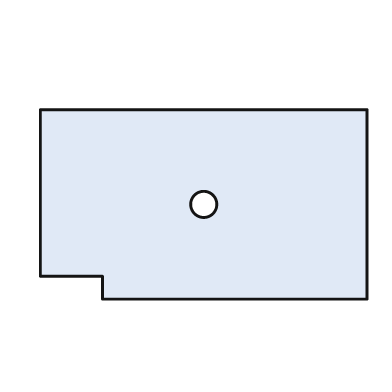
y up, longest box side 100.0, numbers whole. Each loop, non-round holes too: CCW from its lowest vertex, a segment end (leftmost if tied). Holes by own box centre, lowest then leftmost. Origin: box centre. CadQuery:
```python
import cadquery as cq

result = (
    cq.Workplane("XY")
    .moveTo(-31.0, -29.0)
    .lineTo(50.0, -29.0)
    .lineTo(50.0, 29.0)
    .lineTo(-50.0, 29.0)
    .lineTo(-50.0, -22.0)
    .lineTo(-31.0, -22.0)
    .close()
    .moveTo(0.0, 0.0)
    .circle(4.0)
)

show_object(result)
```